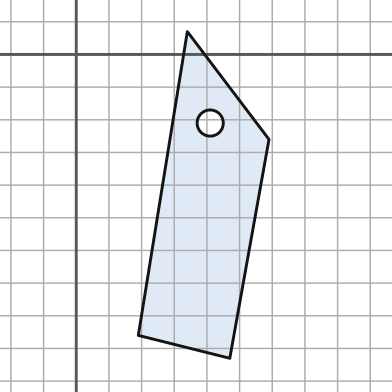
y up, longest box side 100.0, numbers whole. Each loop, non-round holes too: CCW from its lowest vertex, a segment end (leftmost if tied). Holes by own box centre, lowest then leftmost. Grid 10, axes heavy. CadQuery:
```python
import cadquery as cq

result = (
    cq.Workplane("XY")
    .moveTo(47.0, -93.0)
    .lineTo(59.0, -26.0)
    .lineTo(34.0, 7.0)
    .lineTo(19.0, -86.0)
    .close()
    .moveTo(41.0, -21.0)
    .circle(4.0)
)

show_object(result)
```